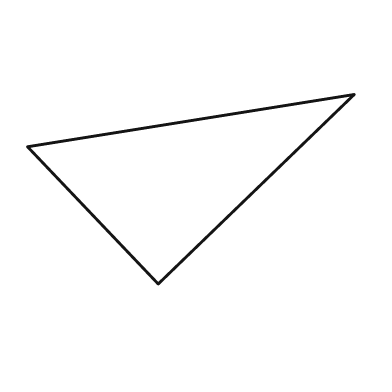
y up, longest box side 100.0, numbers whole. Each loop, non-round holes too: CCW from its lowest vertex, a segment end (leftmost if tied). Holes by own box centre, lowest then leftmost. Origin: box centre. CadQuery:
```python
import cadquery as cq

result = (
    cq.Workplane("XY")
    .moveTo(-10.0, -29.0)
    .lineTo(50.0, 29.0)
    .lineTo(-50.0, 13.0)
    .close()
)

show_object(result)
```